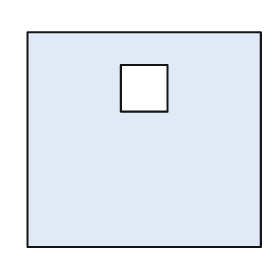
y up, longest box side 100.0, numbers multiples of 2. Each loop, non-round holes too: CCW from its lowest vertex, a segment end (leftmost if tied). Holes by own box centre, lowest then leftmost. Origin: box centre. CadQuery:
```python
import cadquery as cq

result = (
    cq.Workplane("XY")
    .moveTo(-50.0, -46.0)
    .lineTo(50.0, -46.0)
    .lineTo(50.0, 46.0)
    .lineTo(-50.0, 46.0)
    .close()
    .moveTo(-10.0, 12.0)
    .lineTo(10.0, 12.0)
    .lineTo(10.0, 32.0)
    .lineTo(-10.0, 32.0)
    .close()
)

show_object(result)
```